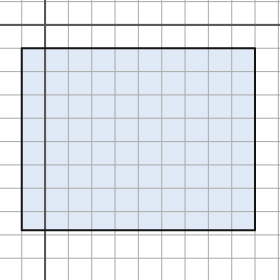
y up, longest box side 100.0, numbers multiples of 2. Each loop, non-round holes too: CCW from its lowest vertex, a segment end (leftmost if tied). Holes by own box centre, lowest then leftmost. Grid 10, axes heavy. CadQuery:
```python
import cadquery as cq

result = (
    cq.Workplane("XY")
    .moveTo(-10.0, -88.0)
    .lineTo(90.0, -88.0)
    .lineTo(90.0, -10.0)
    .lineTo(-10.0, -10.0)
    .close()
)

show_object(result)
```